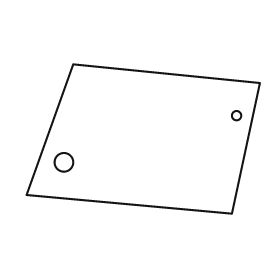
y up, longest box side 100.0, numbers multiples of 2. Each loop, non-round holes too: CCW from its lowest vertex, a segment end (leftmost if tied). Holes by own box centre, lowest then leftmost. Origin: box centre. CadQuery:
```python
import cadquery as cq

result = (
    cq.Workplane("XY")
    .moveTo(38.0, -32.0)
    .lineTo(50.0, 24.0)
    .lineTo(-30.0, 32.0)
    .lineTo(-50.0, -24.0)
    .close()
    .moveTo(-34.0, -10.0)
    .circle(4.0)
    .moveTo(40.0, 10.0)
    .circle(2.0)
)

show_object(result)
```